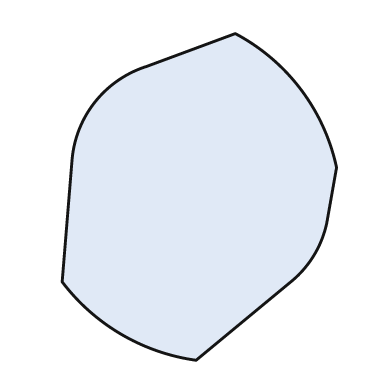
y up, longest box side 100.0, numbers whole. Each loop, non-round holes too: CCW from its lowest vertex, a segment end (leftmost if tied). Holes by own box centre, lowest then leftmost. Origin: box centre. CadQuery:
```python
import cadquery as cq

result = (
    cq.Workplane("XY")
    .moveTo(-1.0, -50.0)
    .lineTo(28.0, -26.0)
    .threePointArc((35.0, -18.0), (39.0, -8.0))
    .lineTo(42.0, 9.0)
    .threePointArc((31.0, 33.0), (11.0, 50.0))
    .lineTo(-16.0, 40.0)
    .threePointArc((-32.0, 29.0), (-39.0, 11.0))
    .lineTo(-42.0, -26.0)
    .threePointArc((-24.0, -42.0), (-1.0, -50.0))
    .close()
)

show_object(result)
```